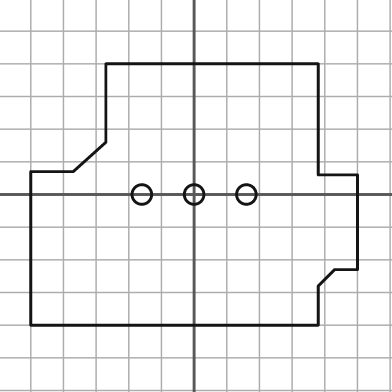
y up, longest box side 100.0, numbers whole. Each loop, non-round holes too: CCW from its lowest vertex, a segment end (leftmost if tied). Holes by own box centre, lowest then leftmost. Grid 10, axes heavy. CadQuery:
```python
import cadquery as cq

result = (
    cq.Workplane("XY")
    .moveTo(-50.0, -40.0)
    .lineTo(38.0, -40.0)
    .lineTo(38.0, -28.0)
    .lineTo(43.0, -23.0)
    .lineTo(50.0, -23.0)
    .lineTo(50.0, 6.0)
    .lineTo(38.0, 6.0)
    .lineTo(38.0, 40.0)
    .lineTo(-27.0, 40.0)
    .lineTo(-27.0, 16.0)
    .lineTo(-37.0, 7.0)
    .lineTo(-50.0, 7.0)
    .close()
    .moveTo(-16.0, 0.0)
    .circle(3.0)
    .moveTo(0.0, 0.0)
    .circle(3.0)
    .moveTo(16.0, 0.0)
    .circle(3.0)
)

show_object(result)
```